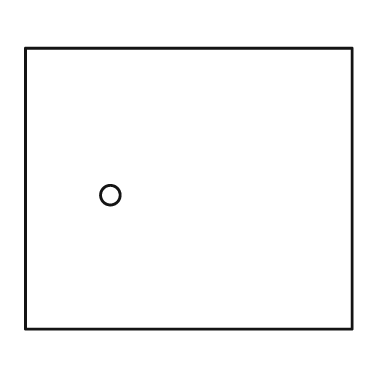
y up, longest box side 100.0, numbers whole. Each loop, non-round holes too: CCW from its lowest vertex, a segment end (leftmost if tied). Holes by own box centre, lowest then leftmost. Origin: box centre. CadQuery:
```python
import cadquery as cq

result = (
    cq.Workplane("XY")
    .moveTo(-50.0, -43.0)
    .lineTo(50.0, -43.0)
    .lineTo(50.0, 43.0)
    .lineTo(-50.0, 43.0)
    .close()
    .moveTo(-24.0, -2.0)
    .circle(3.0)
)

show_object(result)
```